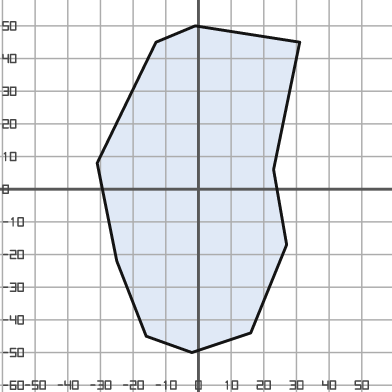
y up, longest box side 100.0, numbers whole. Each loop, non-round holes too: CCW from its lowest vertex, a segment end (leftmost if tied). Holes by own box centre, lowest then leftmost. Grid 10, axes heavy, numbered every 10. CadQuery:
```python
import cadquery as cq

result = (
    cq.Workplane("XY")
    .moveTo(-2.0, -50.0)
    .lineTo(16.0, -44.0)
    .lineTo(27.0, -17.0)
    .lineTo(23.0, 6.0)
    .lineTo(31.0, 45.0)
    .lineTo(-1.0, 50.0)
    .lineTo(-13.0, 45.0)
    .lineTo(-31.0, 8.0)
    .lineTo(-25.0, -22.0)
    .lineTo(-16.0, -45.0)
    .close()
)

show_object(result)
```